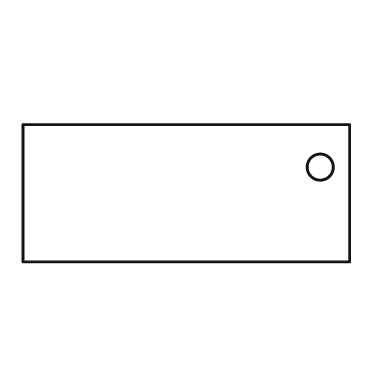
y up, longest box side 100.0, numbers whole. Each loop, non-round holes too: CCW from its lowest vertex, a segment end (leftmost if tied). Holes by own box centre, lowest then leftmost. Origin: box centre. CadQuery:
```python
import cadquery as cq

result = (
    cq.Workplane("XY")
    .moveTo(-50.0, -21.0)
    .lineTo(50.0, -21.0)
    .lineTo(50.0, 21.0)
    .lineTo(-50.0, 21.0)
    .close()
    .moveTo(41.0, 8.0)
    .circle(4.0)
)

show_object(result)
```